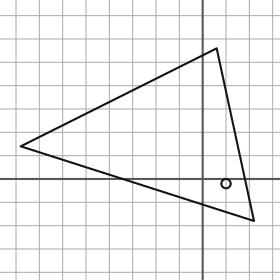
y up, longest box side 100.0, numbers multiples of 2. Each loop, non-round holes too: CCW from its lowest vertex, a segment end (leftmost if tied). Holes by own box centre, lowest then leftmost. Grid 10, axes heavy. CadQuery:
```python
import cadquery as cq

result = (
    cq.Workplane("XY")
    .moveTo(22.0, -18.0)
    .lineTo(6.0, 56.0)
    .lineTo(-78.0, 14.0)
    .close()
    .moveTo(10.0, -2.0)
    .circle(2.0)
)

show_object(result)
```